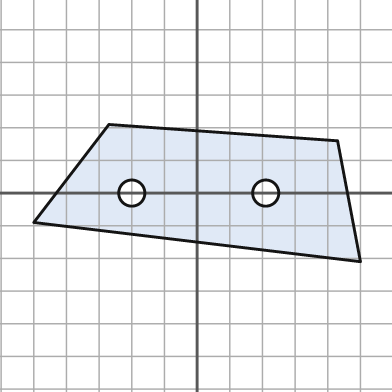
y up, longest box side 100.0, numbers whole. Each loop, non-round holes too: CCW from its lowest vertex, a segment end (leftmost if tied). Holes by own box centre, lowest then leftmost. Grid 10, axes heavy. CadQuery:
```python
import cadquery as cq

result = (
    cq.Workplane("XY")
    .moveTo(50.0, -21.0)
    .lineTo(43.0, 16.0)
    .lineTo(-27.0, 21.0)
    .lineTo(-50.0, -9.0)
    .close()
    .moveTo(-20.0, 0.0)
    .circle(4.0)
    .moveTo(21.0, 0.0)
    .circle(4.0)
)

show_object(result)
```